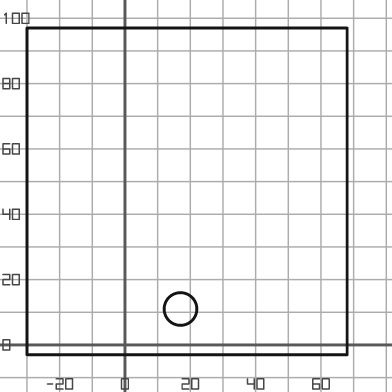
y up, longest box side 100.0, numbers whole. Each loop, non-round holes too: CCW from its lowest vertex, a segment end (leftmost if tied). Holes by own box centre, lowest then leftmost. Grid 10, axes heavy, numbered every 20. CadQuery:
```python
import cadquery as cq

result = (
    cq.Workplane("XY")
    .moveTo(-30.0, -3.0)
    .lineTo(68.0, -3.0)
    .lineTo(68.0, 97.0)
    .lineTo(-30.0, 97.0)
    .close()
    .moveTo(17.0, 11.0)
    .circle(5.0)
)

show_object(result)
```